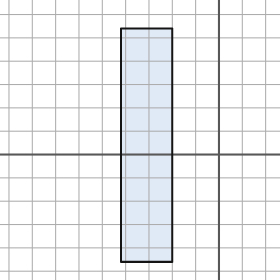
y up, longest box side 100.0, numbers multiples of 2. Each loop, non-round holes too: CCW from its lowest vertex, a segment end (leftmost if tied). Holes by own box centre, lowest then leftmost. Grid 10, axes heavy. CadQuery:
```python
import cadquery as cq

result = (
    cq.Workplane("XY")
    .moveTo(-42.0, -46.0)
    .lineTo(-20.0, -46.0)
    .lineTo(-20.0, 54.0)
    .lineTo(-42.0, 54.0)
    .close()
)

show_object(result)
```